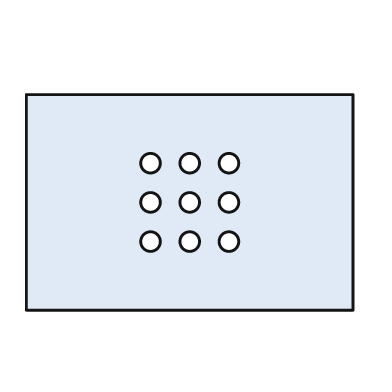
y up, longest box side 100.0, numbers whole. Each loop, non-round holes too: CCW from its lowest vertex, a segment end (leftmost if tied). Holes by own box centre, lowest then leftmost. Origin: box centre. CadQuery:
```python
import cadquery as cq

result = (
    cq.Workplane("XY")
    .moveTo(-50.0, -33.0)
    .lineTo(50.0, -33.0)
    .lineTo(50.0, 33.0)
    .lineTo(-50.0, 33.0)
    .close()
    .moveTo(-12.0, -12.0)
    .circle(3.0)
    .moveTo(0.0, -12.0)
    .circle(3.0)
    .moveTo(12.0, -12.0)
    .circle(3.0)
    .moveTo(-12.0, 0.0)
    .circle(3.0)
    .moveTo(0.0, 0.0)
    .circle(3.0)
    .moveTo(12.0, 0.0)
    .circle(3.0)
    .moveTo(-12.0, 12.0)
    .circle(3.0)
    .moveTo(0.0, 12.0)
    .circle(3.0)
    .moveTo(12.0, 12.0)
    .circle(3.0)
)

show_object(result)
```